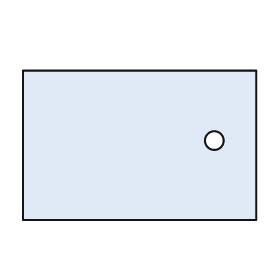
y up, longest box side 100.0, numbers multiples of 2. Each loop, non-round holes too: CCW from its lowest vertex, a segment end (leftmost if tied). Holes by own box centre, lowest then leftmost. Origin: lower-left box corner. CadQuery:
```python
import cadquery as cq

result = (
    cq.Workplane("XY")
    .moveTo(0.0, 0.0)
    .lineTo(100.0, 0.0)
    .lineTo(100.0, 64.0)
    .lineTo(0.0, 64.0)
    .close()
    .moveTo(82.0, 34.0)
    .circle(4.0)
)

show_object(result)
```